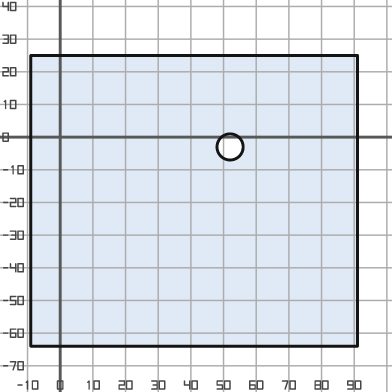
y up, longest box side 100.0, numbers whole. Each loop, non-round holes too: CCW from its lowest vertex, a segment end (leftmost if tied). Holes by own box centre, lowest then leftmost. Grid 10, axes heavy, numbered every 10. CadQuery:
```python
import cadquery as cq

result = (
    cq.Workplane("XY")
    .moveTo(-9.0, -64.0)
    .lineTo(91.0, -64.0)
    .lineTo(91.0, 25.0)
    .lineTo(-9.0, 25.0)
    .close()
    .moveTo(52.0, -3.0)
    .circle(4.0)
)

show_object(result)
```